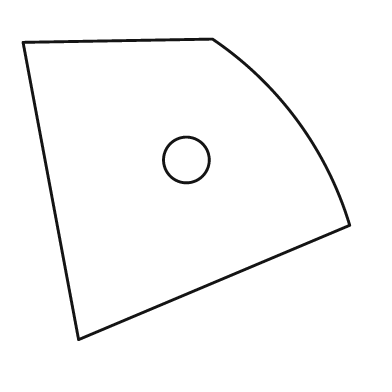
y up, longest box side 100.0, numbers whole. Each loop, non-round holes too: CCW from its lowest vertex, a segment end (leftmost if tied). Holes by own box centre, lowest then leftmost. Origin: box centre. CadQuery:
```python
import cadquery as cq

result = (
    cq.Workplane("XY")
    .moveTo(-33.0, -46.0)
    .lineTo(50.0, -11.0)
    .threePointArc((34.0, 21.0), (8.0, 46.0))
    .lineTo(-50.0, 45.0)
    .close()
    .moveTo(0.0, 9.0)
    .circle(7.0)
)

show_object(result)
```